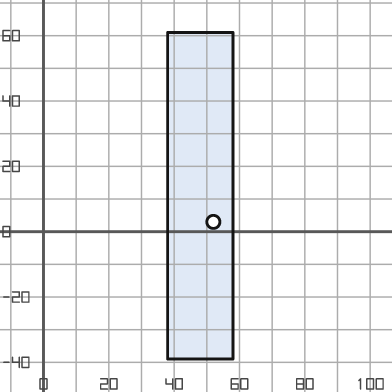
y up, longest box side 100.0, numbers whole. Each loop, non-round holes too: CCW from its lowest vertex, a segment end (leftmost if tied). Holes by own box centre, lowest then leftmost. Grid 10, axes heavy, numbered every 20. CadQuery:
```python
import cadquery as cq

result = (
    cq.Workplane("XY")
    .moveTo(38.0, -39.0)
    .lineTo(58.0, -39.0)
    .lineTo(58.0, 61.0)
    .lineTo(38.0, 61.0)
    .close()
    .moveTo(52.0, 3.0)
    .circle(2.0)
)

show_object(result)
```